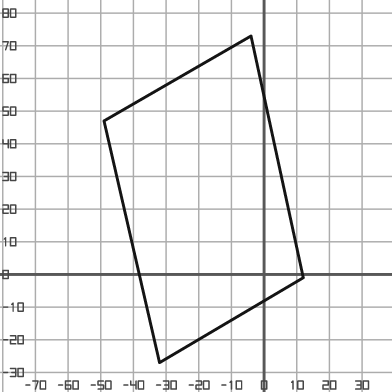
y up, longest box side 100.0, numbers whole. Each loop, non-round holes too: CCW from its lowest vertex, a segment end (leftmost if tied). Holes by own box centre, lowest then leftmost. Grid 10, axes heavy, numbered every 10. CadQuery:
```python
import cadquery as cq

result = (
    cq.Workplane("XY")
    .moveTo(-32.0, -27.0)
    .lineTo(12.0, -1.0)
    .lineTo(-4.0, 73.0)
    .lineTo(-49.0, 47.0)
    .close()
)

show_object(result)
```